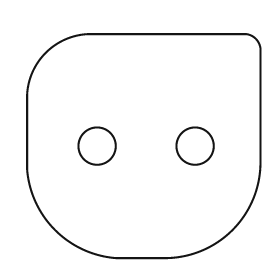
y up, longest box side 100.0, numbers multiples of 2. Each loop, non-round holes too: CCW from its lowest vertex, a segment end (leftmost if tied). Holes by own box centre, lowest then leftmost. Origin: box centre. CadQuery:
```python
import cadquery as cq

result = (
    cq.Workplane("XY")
    .moveTo(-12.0, -48.0)
    .lineTo(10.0, -48.0)
    .threePointArc((38.0, -36.0), (50.0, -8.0))
    .lineTo(50.0, 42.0)
    .threePointArc((48.0, 46.0), (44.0, 48.0))
    .lineTo(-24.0, 48.0)
    .threePointArc((-42.0, 40.0), (-50.0, 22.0))
    .lineTo(-50.0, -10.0)
    .threePointArc((-38.0, -36.0), (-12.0, -48.0))
    .close()
    .moveTo(-20.0, 0.0)
    .circle(8.0)
    .moveTo(22.0, 0.0)
    .circle(8.0)
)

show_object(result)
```